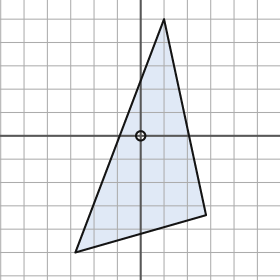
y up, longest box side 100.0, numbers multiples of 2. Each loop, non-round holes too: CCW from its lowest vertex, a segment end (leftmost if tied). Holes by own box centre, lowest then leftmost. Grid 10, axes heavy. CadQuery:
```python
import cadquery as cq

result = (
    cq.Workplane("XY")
    .moveTo(-28.0, -50.0)
    .lineTo(28.0, -34.0)
    .lineTo(10.0, 50.0)
    .close()
    .moveTo(0.0, 0.0)
    .circle(2.0)
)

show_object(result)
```